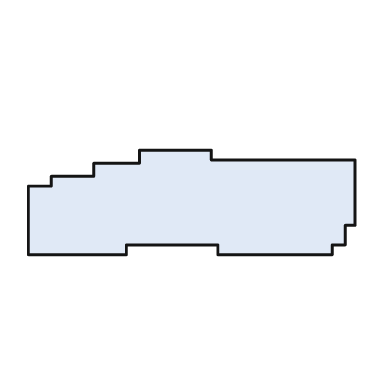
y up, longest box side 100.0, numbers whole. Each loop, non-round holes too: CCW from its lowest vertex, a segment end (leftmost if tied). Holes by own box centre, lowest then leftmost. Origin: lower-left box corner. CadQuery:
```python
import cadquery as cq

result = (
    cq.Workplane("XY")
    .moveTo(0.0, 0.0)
    .lineTo(30.0, 0.0)
    .lineTo(30.0, 3.0)
    .lineTo(58.0, 3.0)
    .lineTo(58.0, 0.0)
    .lineTo(93.0, 0.0)
    .lineTo(93.0, 3.0)
    .lineTo(97.0, 3.0)
    .lineTo(97.0, 9.0)
    .lineTo(100.0, 9.0)
    .lineTo(100.0, 29.0)
    .lineTo(56.0, 29.0)
    .lineTo(56.0, 32.0)
    .lineTo(34.0, 32.0)
    .lineTo(34.0, 28.0)
    .lineTo(20.0, 28.0)
    .lineTo(20.0, 24.0)
    .lineTo(7.0, 24.0)
    .lineTo(7.0, 21.0)
    .lineTo(0.0, 21.0)
    .close()
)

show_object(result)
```